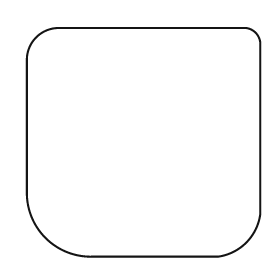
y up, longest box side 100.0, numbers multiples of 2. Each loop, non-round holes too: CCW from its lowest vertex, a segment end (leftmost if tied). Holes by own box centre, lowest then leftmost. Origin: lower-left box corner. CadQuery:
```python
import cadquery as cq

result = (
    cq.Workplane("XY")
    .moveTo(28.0, 0.0)
    .lineTo(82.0, 0.0)
    .threePointArc((94.0, 6.0), (100.0, 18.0))
    .lineTo(100.0, 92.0)
    .threePointArc((98.0, 96.0), (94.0, 98.0))
    .lineTo(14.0, 98.0)
    .threePointArc((4.0, 94.0), (0.0, 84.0))
    .lineTo(0.0, 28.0)
    .threePointArc((8.0, 8.0), (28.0, 0.0))
    .close()
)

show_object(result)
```